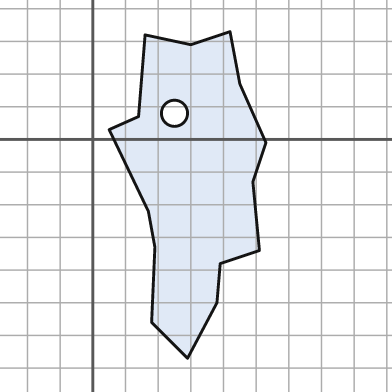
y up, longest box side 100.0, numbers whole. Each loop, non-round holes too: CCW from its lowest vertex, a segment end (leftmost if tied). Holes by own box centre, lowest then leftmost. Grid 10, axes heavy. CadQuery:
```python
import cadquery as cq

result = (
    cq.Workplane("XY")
    .moveTo(29.0, -67.0)
    .lineTo(38.0, -50.0)
    .lineTo(39.0, -38.0)
    .lineTo(51.0, -34.0)
    .lineTo(49.0, -13.0)
    .lineTo(53.0, -1.0)
    .lineTo(45.0, 17.0)
    .lineTo(42.0, 33.0)
    .lineTo(30.0, 29.0)
    .lineTo(16.0, 32.0)
    .lineTo(14.0, 7.0)
    .lineTo(5.0, 3.0)
    .lineTo(17.0, -22.0)
    .lineTo(19.0, -33.0)
    .lineTo(18.0, -56.0)
    .close()
    .moveTo(25.0, 8.0)
    .circle(4.0)
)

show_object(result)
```